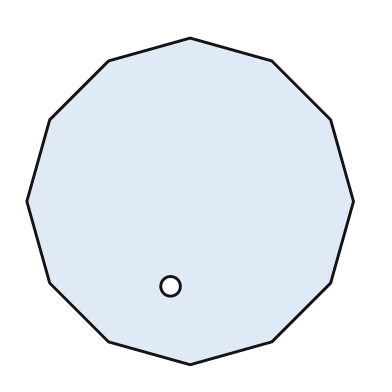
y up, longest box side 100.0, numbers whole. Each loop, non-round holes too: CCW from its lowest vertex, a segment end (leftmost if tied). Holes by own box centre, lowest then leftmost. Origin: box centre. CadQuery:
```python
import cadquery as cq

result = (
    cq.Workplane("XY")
    .moveTo(0.0, -50.0)
    .lineTo(25.0, -43.0)
    .lineTo(43.0, -25.0)
    .lineTo(50.0, 0.0)
    .lineTo(43.0, 25.0)
    .lineTo(25.0, 43.0)
    .lineTo(0.0, 50.0)
    .lineTo(-25.0, 43.0)
    .lineTo(-43.0, 25.0)
    .lineTo(-50.0, 0.0)
    .lineTo(-43.0, -25.0)
    .lineTo(-25.0, -43.0)
    .close()
    .moveTo(-6.0, -26.0)
    .circle(3.0)
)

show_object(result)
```